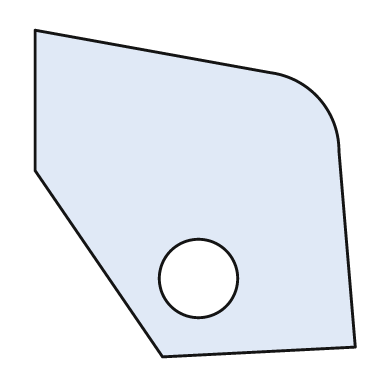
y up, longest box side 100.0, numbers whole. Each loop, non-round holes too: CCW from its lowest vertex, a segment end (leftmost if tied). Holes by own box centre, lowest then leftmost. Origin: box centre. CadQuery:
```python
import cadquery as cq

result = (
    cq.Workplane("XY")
    .moveTo(-10.0, -50.0)
    .lineTo(49.0, -47.0)
    .lineTo(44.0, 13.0)
    .threePointArc((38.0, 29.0), (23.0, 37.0))
    .lineTo(-49.0, 50.0)
    .lineTo(-49.0, 7.0)
    .close()
    .moveTo(1.0, -26.0)
    .circle(12.0)
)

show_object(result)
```